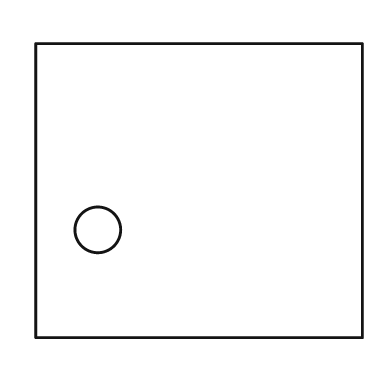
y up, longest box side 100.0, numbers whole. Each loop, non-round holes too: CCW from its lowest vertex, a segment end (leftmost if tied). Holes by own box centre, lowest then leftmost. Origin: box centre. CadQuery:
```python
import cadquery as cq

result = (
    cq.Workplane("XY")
    .moveTo(-50.0, -45.0)
    .lineTo(50.0, -45.0)
    .lineTo(50.0, 45.0)
    .lineTo(-50.0, 45.0)
    .close()
    .moveTo(-31.0, -12.0)
    .circle(7.0)
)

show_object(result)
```